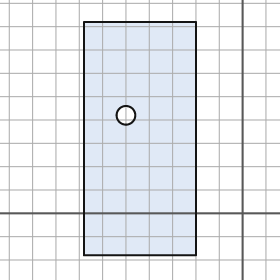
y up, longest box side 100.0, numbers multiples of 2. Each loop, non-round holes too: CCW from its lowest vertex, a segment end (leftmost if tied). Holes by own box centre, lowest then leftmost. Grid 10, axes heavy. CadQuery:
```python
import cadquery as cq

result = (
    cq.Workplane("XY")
    .moveTo(-68.0, -18.0)
    .lineTo(-20.0, -18.0)
    .lineTo(-20.0, 82.0)
    .lineTo(-68.0, 82.0)
    .close()
    .moveTo(-50.0, 42.0)
    .circle(4.0)
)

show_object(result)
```